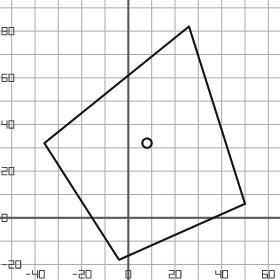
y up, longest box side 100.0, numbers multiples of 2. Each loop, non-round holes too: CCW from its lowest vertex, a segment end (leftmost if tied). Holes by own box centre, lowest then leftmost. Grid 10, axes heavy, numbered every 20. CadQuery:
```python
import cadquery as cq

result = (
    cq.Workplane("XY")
    .moveTo(-4.0, -18.0)
    .lineTo(50.0, 6.0)
    .lineTo(26.0, 82.0)
    .lineTo(-36.0, 32.0)
    .close()
    .moveTo(8.0, 32.0)
    .circle(2.0)
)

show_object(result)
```